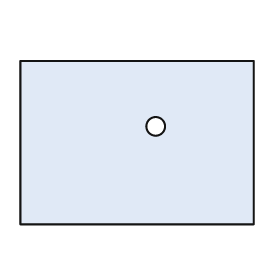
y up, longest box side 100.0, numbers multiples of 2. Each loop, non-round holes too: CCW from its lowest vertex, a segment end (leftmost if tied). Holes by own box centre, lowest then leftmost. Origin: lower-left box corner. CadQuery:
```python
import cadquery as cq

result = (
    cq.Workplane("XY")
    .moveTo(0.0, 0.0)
    .lineTo(100.0, 0.0)
    .lineTo(100.0, 70.0)
    .lineTo(0.0, 70.0)
    .close()
    .moveTo(58.0, 42.0)
    .circle(4.0)
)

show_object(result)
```